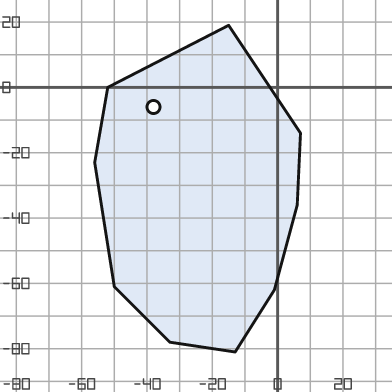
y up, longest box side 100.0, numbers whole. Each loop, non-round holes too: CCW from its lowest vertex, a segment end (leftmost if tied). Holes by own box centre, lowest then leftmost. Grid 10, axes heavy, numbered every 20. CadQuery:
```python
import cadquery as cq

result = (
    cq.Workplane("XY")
    .moveTo(-13.0, -81.0)
    .lineTo(-1.0, -62.0)
    .lineTo(6.0, -36.0)
    .lineTo(7.0, -14.0)
    .lineTo(-15.0, 19.0)
    .lineTo(-52.0, 0.0)
    .lineTo(-56.0, -23.0)
    .lineTo(-50.0, -61.0)
    .lineTo(-33.0, -78.0)
    .close()
    .moveTo(-38.0, -6.0)
    .circle(2.0)
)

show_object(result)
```